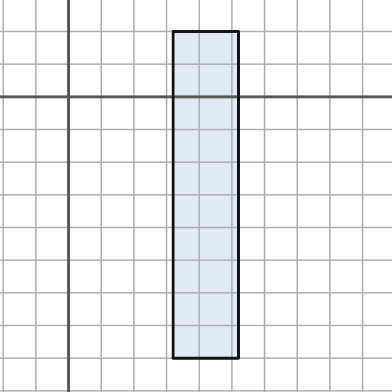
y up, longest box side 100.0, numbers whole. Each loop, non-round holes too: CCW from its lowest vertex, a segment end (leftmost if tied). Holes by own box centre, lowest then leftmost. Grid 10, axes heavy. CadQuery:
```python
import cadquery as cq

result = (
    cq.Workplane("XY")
    .moveTo(32.0, -80.0)
    .lineTo(52.0, -80.0)
    .lineTo(52.0, 20.0)
    .lineTo(32.0, 20.0)
    .close()
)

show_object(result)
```